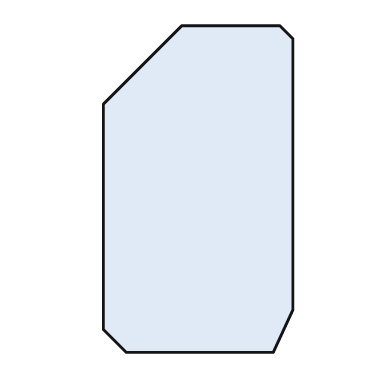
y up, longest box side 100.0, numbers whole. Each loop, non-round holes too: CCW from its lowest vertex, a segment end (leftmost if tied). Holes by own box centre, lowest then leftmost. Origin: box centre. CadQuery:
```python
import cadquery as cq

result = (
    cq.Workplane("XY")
    .moveTo(-22.0, -50.0)
    .lineTo(23.0, -50.0)
    .lineTo(29.0, -37.0)
    .lineTo(29.0, 46.0)
    .lineTo(25.0, 50.0)
    .lineTo(-5.0, 50.0)
    .lineTo(-29.0, 26.0)
    .lineTo(-29.0, -43.0)
    .close()
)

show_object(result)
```